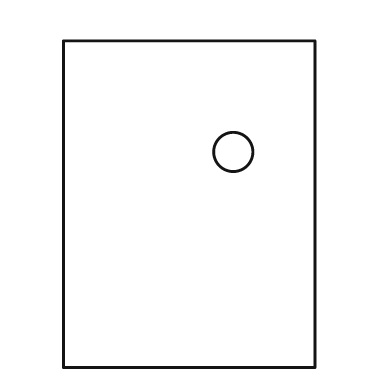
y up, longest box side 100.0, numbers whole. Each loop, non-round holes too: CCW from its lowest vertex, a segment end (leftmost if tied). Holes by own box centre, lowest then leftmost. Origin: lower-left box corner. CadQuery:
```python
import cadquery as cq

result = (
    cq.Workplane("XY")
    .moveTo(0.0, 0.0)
    .lineTo(77.0, 0.0)
    .lineTo(77.0, 100.0)
    .lineTo(0.0, 100.0)
    .close()
    .moveTo(52.0, 66.0)
    .circle(6.0)
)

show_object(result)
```